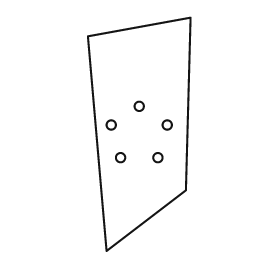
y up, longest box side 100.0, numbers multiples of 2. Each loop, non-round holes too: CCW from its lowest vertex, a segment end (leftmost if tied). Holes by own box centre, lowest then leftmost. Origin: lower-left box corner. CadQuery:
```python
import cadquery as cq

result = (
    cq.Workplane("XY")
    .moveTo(8.0, 0.0)
    .lineTo(42.0, 26.0)
    .lineTo(44.0, 100.0)
    .lineTo(0.0, 92.0)
    .close()
    .moveTo(14.0, 40.0)
    .circle(2.0)
    .moveTo(30.0, 40.0)
    .circle(2.0)
    .moveTo(10.0, 54.0)
    .circle(2.0)
    .moveTo(34.0, 54.0)
    .circle(2.0)
    .moveTo(22.0, 62.0)
    .circle(2.0)
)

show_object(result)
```